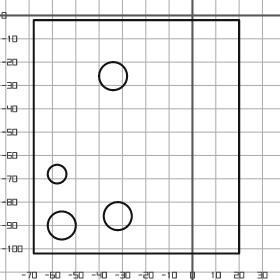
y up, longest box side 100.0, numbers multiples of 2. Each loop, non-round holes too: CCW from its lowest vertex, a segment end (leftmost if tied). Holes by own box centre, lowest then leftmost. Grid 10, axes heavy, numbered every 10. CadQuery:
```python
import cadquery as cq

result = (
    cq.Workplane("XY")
    .moveTo(-68.0, -102.0)
    .lineTo(20.0, -102.0)
    .lineTo(20.0, -2.0)
    .lineTo(-68.0, -2.0)
    .close()
    .moveTo(-56.0, -90.0)
    .circle(6.0)
    .moveTo(-32.0, -86.0)
    .circle(6.0)
    .moveTo(-58.0, -68.0)
    .circle(4.0)
    .moveTo(-34.0, -26.0)
    .circle(6.0)
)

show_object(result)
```